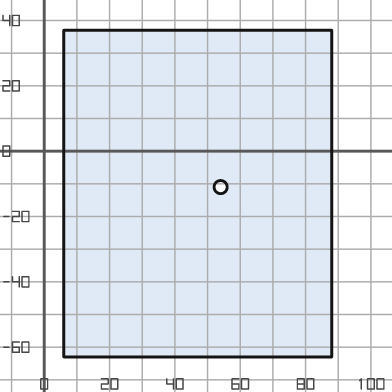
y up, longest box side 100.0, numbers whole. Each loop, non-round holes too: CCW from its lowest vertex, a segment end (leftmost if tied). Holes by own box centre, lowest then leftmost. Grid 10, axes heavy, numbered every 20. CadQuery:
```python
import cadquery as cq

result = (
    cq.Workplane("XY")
    .moveTo(6.0, -63.0)
    .lineTo(88.0, -63.0)
    .lineTo(88.0, 37.0)
    .lineTo(6.0, 37.0)
    .close()
    .moveTo(54.0, -11.0)
    .circle(2.0)
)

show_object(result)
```